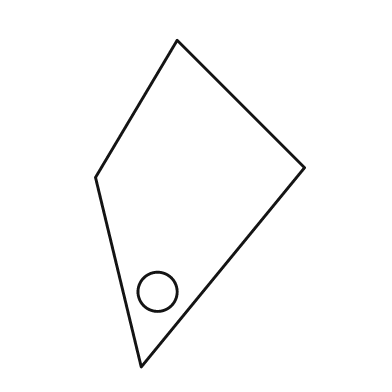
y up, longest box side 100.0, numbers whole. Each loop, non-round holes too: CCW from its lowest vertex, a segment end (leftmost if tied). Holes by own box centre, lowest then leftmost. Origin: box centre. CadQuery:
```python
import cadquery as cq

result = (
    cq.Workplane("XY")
    .moveTo(-18.0, -50.0)
    .lineTo(32.0, 11.0)
    .lineTo(-7.0, 50.0)
    .lineTo(-32.0, 8.0)
    .close()
    .moveTo(-13.0, -27.0)
    .circle(6.0)
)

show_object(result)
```